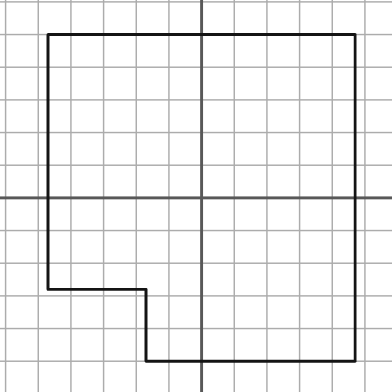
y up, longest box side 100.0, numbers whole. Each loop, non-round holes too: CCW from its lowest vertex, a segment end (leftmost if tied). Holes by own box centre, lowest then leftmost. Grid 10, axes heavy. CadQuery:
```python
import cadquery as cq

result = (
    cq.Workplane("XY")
    .moveTo(-17.0, -50.0)
    .lineTo(47.0, -50.0)
    .lineTo(47.0, 50.0)
    .lineTo(-47.0, 50.0)
    .lineTo(-47.0, -28.0)
    .lineTo(-17.0, -28.0)
    .close()
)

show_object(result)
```